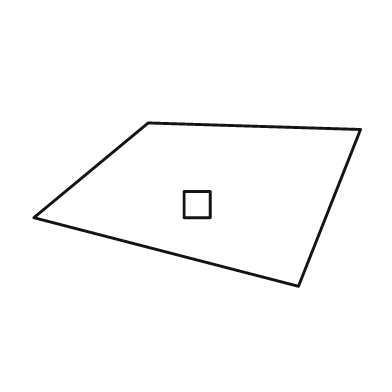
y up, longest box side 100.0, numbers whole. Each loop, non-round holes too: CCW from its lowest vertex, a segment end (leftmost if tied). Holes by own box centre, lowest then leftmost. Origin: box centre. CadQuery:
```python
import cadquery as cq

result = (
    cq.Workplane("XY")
    .moveTo(31.0, -25.0)
    .lineTo(50.0, 23.0)
    .lineTo(-15.0, 25.0)
    .lineTo(-50.0, -4.0)
    .close()
    .moveTo(-4.0, -4.0)
    .lineTo(4.0, -4.0)
    .lineTo(4.0, 4.0)
    .lineTo(-4.0, 4.0)
    .close()
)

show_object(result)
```